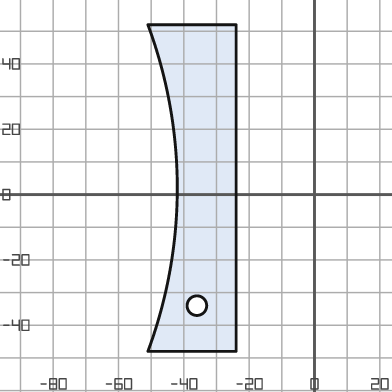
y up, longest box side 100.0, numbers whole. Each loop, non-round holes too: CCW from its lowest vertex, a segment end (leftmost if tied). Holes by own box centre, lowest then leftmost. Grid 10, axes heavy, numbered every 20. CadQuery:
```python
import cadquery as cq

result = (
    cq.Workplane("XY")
    .moveTo(-51.0, -48.0)
    .lineTo(-24.0, -48.0)
    .lineTo(-24.0, 52.0)
    .lineTo(-51.0, 52.0)
    .threePointArc((-42.0, 2.0), (-51.0, -48.0))
    .close()
    .moveTo(-36.0, -34.0)
    .circle(3.0)
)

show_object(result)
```